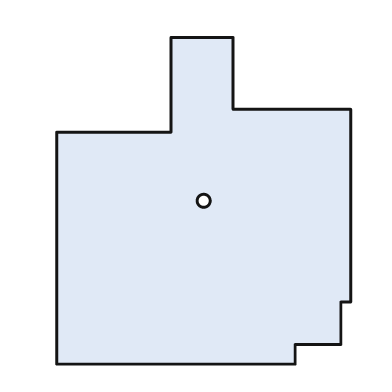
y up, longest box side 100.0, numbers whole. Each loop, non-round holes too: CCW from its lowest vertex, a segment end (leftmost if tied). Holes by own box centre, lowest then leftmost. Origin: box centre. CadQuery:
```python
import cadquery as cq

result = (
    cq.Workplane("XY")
    .moveTo(-45.0, -50.0)
    .lineTo(28.0, -50.0)
    .lineTo(28.0, -44.0)
    .lineTo(42.0, -44.0)
    .lineTo(42.0, -31.0)
    .lineTo(45.0, -31.0)
    .lineTo(45.0, 28.0)
    .lineTo(9.0, 28.0)
    .lineTo(9.0, 50.0)
    .lineTo(-10.0, 50.0)
    .lineTo(-10.0, 21.0)
    .lineTo(-45.0, 21.0)
    .close()
    .moveTo(0.0, 0.0)
    .circle(2.0)
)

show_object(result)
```